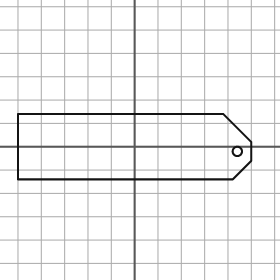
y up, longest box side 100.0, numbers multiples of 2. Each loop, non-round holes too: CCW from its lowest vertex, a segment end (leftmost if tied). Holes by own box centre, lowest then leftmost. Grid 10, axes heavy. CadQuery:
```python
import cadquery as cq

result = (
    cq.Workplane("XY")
    .moveTo(-50.0, -14.0)
    .lineTo(42.0, -14.0)
    .lineTo(50.0, -6.0)
    .lineTo(50.0, 2.0)
    .lineTo(38.0, 14.0)
    .lineTo(-50.0, 14.0)
    .close()
    .moveTo(44.0, -2.0)
    .circle(2.0)
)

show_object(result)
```